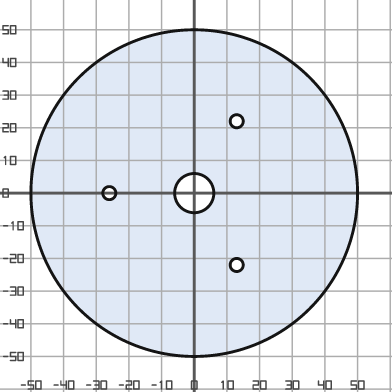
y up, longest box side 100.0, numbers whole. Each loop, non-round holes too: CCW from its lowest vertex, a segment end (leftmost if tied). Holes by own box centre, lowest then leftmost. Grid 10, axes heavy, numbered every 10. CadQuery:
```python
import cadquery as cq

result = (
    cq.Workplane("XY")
    .moveTo(0.0, 0.0)
    .circle(50.0)
    .moveTo(13.0, -22.0)
    .circle(2.0)
    .moveTo(-26.0, 0.0)
    .circle(2.0)
    .moveTo(0.0, 0.0)
    .circle(6.0)
    .moveTo(13.0, 22.0)
    .circle(2.0)
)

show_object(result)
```